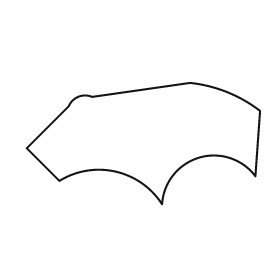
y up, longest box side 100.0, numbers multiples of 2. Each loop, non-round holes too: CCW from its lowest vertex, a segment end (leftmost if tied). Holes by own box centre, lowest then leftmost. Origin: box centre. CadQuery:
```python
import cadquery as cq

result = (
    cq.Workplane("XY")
    .moveTo(8.0, -26.0)
    .threePointArc((24.0, -6.0), (48.0, -14.0))
    .lineTo(50.0, 14.0)
    .threePointArc((36.0, 22.0), (20.0, 26.0))
    .lineTo(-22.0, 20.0)
    .threePointArc((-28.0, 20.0), (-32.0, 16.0))
    .lineTo(-50.0, -2.0)
    .lineTo(-36.0, -16.0)
    .threePointArc((-12.0, -12.0), (8.0, -26.0))
    .close()
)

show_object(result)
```